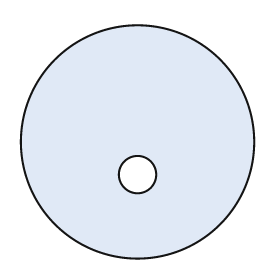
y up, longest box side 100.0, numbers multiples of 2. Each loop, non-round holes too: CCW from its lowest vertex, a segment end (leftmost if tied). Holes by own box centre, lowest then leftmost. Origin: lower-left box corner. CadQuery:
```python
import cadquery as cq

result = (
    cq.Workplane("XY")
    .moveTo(50.0, 50.0)
    .circle(50.0)
    .moveTo(50.0, 36.0)
    .circle(8.0)
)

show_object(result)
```